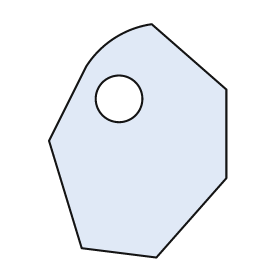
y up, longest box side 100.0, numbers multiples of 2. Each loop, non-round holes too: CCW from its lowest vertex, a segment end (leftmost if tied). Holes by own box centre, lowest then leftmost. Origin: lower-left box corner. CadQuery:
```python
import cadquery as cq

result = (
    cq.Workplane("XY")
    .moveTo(46.0, 0.0)
    .lineTo(76.0, 34.0)
    .lineTo(76.0, 72.0)
    .lineTo(44.0, 100.0)
    .threePointArc((28.0, 94.0), (16.0, 82.0))
    .lineTo(0.0, 50.0)
    .lineTo(14.0, 4.0)
    .close()
    .moveTo(30.0, 68.0)
    .circle(10.0)
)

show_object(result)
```